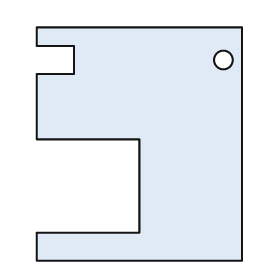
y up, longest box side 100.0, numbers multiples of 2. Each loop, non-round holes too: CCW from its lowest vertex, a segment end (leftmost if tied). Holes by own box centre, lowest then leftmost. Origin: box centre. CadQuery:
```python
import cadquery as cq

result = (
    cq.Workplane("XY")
    .moveTo(-44.0, -50.0)
    .lineTo(44.0, -50.0)
    .lineTo(44.0, 50.0)
    .lineTo(-44.0, 50.0)
    .lineTo(-44.0, 42.0)
    .lineTo(-28.0, 42.0)
    .lineTo(-28.0, 30.0)
    .lineTo(-44.0, 30.0)
    .lineTo(-44.0, 2.0)
    .lineTo(0.0, 2.0)
    .lineTo(0.0, -38.0)
    .lineTo(-44.0, -38.0)
    .close()
    .moveTo(36.0, 36.0)
    .circle(4.0)
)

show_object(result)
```